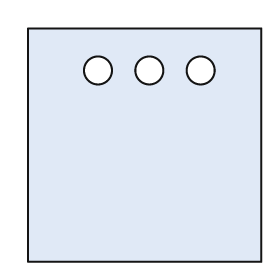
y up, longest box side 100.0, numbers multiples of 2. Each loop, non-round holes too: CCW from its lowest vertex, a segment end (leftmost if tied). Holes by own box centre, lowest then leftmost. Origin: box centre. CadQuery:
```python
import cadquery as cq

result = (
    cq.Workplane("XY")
    .moveTo(-50.0, -50.0)
    .lineTo(50.0, -50.0)
    .lineTo(50.0, 50.0)
    .lineTo(-50.0, 50.0)
    .close()
    .moveTo(-20.0, 32.0)
    .circle(6.0)
    .moveTo(2.0, 32.0)
    .circle(6.0)
    .moveTo(24.0, 32.0)
    .circle(6.0)
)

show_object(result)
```